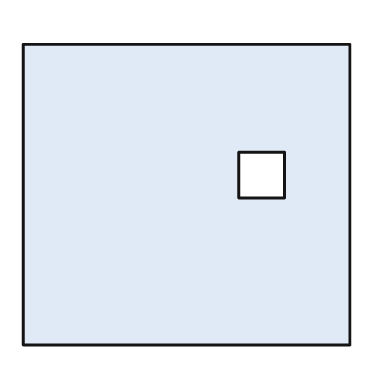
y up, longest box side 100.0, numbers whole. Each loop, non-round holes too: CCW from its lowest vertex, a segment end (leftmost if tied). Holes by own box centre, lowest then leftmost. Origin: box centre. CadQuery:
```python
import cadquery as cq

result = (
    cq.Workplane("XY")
    .moveTo(-50.0, -46.0)
    .lineTo(50.0, -46.0)
    .lineTo(50.0, 46.0)
    .lineTo(-50.0, 46.0)
    .close()
    .moveTo(16.0, -1.0)
    .lineTo(30.0, -1.0)
    .lineTo(30.0, 13.0)
    .lineTo(16.0, 13.0)
    .close()
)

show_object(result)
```